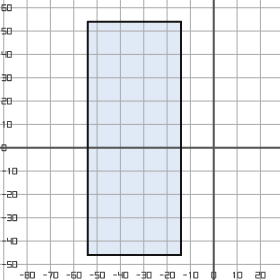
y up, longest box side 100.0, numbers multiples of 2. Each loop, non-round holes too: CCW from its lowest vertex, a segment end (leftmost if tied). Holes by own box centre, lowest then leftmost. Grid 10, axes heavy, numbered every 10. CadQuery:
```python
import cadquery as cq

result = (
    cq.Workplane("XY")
    .moveTo(-54.0, -46.0)
    .lineTo(-14.0, -46.0)
    .lineTo(-14.0, 54.0)
    .lineTo(-54.0, 54.0)
    .close()
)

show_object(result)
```